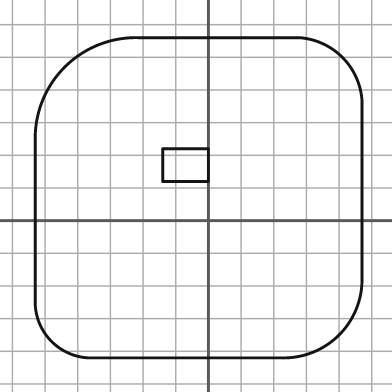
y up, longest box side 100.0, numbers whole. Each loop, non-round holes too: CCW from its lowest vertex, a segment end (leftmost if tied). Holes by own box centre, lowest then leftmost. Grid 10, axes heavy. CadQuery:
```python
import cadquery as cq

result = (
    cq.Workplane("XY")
    .moveTo(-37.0, -42.0)
    .lineTo(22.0, -42.0)
    .threePointArc((40.0, -35.0), (47.0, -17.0))
    .lineTo(47.0, 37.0)
    .threePointArc((41.0, 50.0), (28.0, 56.0))
    .lineTo(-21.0, 56.0)
    .threePointArc((-44.0, 47.0), (-53.0, 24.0))
    .lineTo(-53.0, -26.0)
    .threePointArc((-48.0, -37.0), (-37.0, -42.0))
    .close()
    .moveTo(-14.0, 12.0)
    .lineTo(0.0, 12.0)
    .lineTo(0.0, 22.0)
    .lineTo(-14.0, 22.0)
    .close()
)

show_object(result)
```